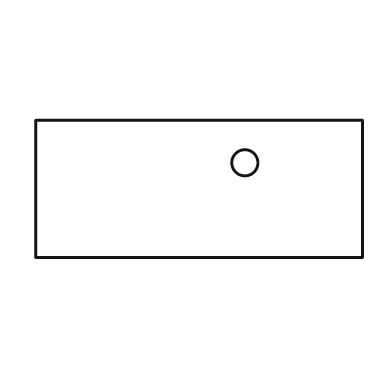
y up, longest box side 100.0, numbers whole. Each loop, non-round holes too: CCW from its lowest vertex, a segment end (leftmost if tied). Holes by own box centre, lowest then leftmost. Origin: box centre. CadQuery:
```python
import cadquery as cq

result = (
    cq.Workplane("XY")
    .moveTo(-50.0, -21.0)
    .lineTo(50.0, -21.0)
    .lineTo(50.0, 21.0)
    .lineTo(-50.0, 21.0)
    .close()
    .moveTo(14.0, 8.0)
    .circle(4.0)
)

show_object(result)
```